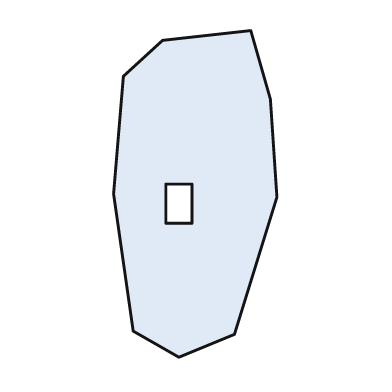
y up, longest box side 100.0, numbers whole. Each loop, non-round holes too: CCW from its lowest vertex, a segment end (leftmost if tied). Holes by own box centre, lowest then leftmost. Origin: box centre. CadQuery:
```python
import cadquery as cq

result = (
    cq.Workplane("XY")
    .moveTo(-5.0, -50.0)
    .lineTo(12.0, -43.0)
    .lineTo(25.0, -1.0)
    .lineTo(23.0, 29.0)
    .lineTo(17.0, 50.0)
    .lineTo(-10.0, 47.0)
    .lineTo(-22.0, 36.0)
    .lineTo(-25.0, 0.0)
    .lineTo(-19.0, -42.0)
    .close()
    .moveTo(-9.0, -9.0)
    .lineTo(-1.0, -9.0)
    .lineTo(-1.0, 3.0)
    .lineTo(-9.0, 3.0)
    .close()
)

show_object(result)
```